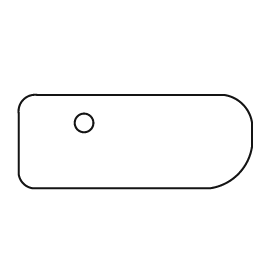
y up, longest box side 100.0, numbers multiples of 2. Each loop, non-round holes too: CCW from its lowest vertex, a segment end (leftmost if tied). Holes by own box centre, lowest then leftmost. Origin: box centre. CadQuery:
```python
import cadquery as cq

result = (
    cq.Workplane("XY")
    .moveTo(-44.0, -20.0)
    .lineTo(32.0, -20.0)
    .threePointArc((44.0, -14.0), (50.0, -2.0))
    .lineTo(50.0, 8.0)
    .threePointArc((46.0, 16.0), (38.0, 20.0))
    .lineTo(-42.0, 20.0)
    .threePointArc((-48.0, 18.0), (-50.0, 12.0))
    .lineTo(-50.0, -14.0)
    .threePointArc((-48.0, -18.0), (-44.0, -20.0))
    .close()
    .moveTo(-22.0, 8.0)
    .circle(4.0)
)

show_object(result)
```